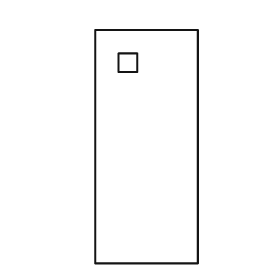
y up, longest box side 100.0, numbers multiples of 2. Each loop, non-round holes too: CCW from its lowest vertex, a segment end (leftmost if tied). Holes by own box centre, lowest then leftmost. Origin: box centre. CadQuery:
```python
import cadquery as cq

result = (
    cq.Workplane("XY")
    .moveTo(-22.0, -50.0)
    .lineTo(22.0, -50.0)
    .lineTo(22.0, 50.0)
    .lineTo(-22.0, 50.0)
    .close()
    .moveTo(-12.0, 32.0)
    .lineTo(-4.0, 32.0)
    .lineTo(-4.0, 40.0)
    .lineTo(-12.0, 40.0)
    .close()
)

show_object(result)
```